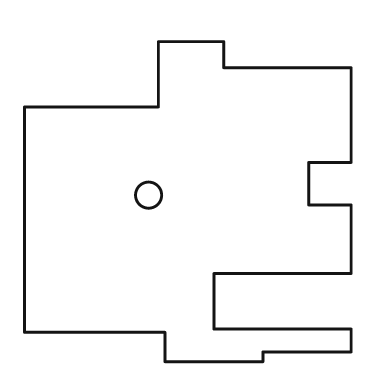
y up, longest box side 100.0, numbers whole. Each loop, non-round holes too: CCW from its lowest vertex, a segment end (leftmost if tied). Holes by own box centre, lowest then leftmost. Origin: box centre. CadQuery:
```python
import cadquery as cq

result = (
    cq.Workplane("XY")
    .moveTo(-7.0, -49.0)
    .lineTo(23.0, -49.0)
    .lineTo(23.0, -46.0)
    .lineTo(50.0, -46.0)
    .lineTo(50.0, -39.0)
    .lineTo(8.0, -39.0)
    .lineTo(8.0, -22.0)
    .lineTo(50.0, -22.0)
    .lineTo(50.0, -1.0)
    .lineTo(37.0, -1.0)
    .lineTo(37.0, 12.0)
    .lineTo(50.0, 12.0)
    .lineTo(50.0, 41.0)
    .lineTo(11.0, 41.0)
    .lineTo(11.0, 49.0)
    .lineTo(-9.0, 49.0)
    .lineTo(-9.0, 29.0)
    .lineTo(-50.0, 29.0)
    .lineTo(-50.0, -40.0)
    .lineTo(-7.0, -40.0)
    .close()
    .moveTo(-12.0, 2.0)
    .circle(4.0)
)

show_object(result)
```